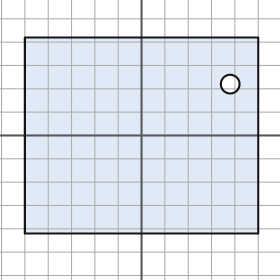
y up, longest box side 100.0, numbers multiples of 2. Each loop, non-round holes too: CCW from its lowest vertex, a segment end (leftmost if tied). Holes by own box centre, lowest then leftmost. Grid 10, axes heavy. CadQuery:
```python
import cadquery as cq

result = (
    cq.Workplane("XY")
    .moveTo(-50.0, -42.0)
    .lineTo(50.0, -42.0)
    .lineTo(50.0, 42.0)
    .lineTo(-50.0, 42.0)
    .close()
    .moveTo(38.0, 22.0)
    .circle(4.0)
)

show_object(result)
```